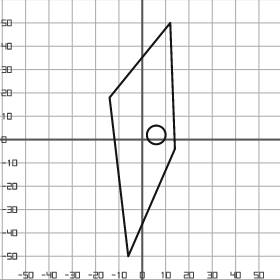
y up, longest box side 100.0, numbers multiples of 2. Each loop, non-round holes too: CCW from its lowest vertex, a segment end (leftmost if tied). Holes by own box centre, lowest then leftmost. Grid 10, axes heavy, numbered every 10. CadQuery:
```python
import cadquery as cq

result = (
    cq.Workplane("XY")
    .moveTo(-6.0, -50.0)
    .lineTo(14.0, -4.0)
    .lineTo(12.0, 50.0)
    .lineTo(-14.0, 18.0)
    .close()
    .moveTo(6.0, 2.0)
    .circle(4.0)
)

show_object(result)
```